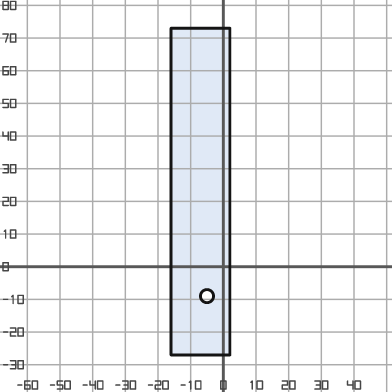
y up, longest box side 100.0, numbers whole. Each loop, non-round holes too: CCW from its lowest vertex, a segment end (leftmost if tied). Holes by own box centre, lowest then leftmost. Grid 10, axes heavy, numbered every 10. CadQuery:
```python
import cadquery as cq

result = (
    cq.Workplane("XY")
    .moveTo(-16.0, -27.0)
    .lineTo(2.0, -27.0)
    .lineTo(2.0, 73.0)
    .lineTo(-16.0, 73.0)
    .close()
    .moveTo(-5.0, -9.0)
    .circle(2.0)
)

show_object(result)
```